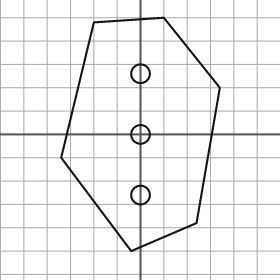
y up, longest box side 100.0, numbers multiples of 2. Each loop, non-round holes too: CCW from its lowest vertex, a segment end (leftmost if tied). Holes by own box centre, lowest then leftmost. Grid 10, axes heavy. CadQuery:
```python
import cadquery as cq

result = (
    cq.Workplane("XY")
    .moveTo(-4.0, -50.0)
    .lineTo(24.0, -38.0)
    .lineTo(34.0, 20.0)
    .lineTo(10.0, 50.0)
    .lineTo(-20.0, 48.0)
    .lineTo(-34.0, -10.0)
    .close()
    .moveTo(0.0, -26.0)
    .circle(4.0)
    .moveTo(0.0, 0.0)
    .circle(4.0)
    .moveTo(0.0, 26.0)
    .circle(4.0)
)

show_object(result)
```